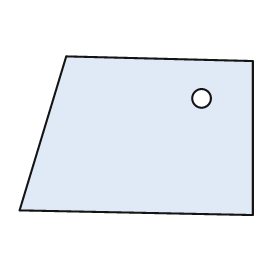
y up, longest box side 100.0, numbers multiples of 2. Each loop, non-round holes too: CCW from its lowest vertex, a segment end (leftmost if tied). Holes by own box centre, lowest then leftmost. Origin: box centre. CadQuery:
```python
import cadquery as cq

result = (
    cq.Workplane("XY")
    .moveTo(50.0, -34.0)
    .lineTo(50.0, 32.0)
    .lineTo(-30.0, 34.0)
    .lineTo(-50.0, -32.0)
    .close()
    .moveTo(28.0, 16.0)
    .circle(4.0)
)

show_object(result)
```